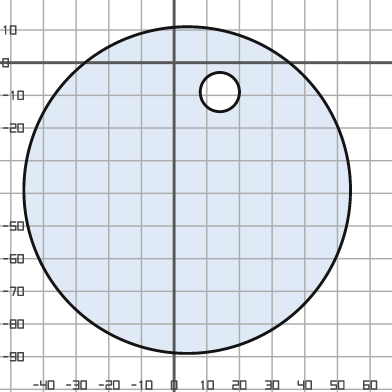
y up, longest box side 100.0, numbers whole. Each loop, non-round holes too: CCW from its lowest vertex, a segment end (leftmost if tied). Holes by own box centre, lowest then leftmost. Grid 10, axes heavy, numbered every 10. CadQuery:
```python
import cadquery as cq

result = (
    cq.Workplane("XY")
    .moveTo(4.0, -39.0)
    .circle(50.0)
    .moveTo(14.0, -9.0)
    .circle(6.0)
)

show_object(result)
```